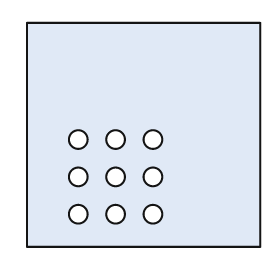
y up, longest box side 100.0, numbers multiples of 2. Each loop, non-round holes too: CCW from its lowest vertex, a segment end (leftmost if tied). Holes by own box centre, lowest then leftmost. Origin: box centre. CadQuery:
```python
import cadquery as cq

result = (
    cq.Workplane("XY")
    .moveTo(-50.0, -48.0)
    .lineTo(50.0, -48.0)
    .lineTo(50.0, 48.0)
    .lineTo(-50.0, 48.0)
    .close()
    .moveTo(-28.0, -34.0)
    .circle(4.0)
    .moveTo(-12.0, -34.0)
    .circle(4.0)
    .moveTo(4.0, -34.0)
    .circle(4.0)
    .moveTo(-28.0, -18.0)
    .circle(4.0)
    .moveTo(-12.0, -18.0)
    .circle(4.0)
    .moveTo(4.0, -18.0)
    .circle(4.0)
    .moveTo(-28.0, -2.0)
    .circle(4.0)
    .moveTo(-12.0, -2.0)
    .circle(4.0)
    .moveTo(4.0, -2.0)
    .circle(4.0)
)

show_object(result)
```